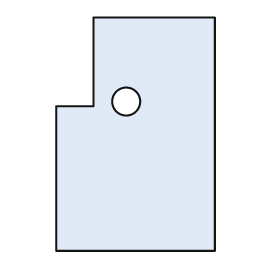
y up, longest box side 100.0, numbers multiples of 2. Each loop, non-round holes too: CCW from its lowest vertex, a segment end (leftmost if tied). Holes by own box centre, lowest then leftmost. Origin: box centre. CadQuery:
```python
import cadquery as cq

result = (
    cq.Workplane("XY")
    .moveTo(-34.0, -50.0)
    .lineTo(34.0, -50.0)
    .lineTo(34.0, 50.0)
    .lineTo(-18.0, 50.0)
    .lineTo(-18.0, 12.0)
    .lineTo(-34.0, 12.0)
    .close()
    .moveTo(-4.0, 14.0)
    .circle(6.0)
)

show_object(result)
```